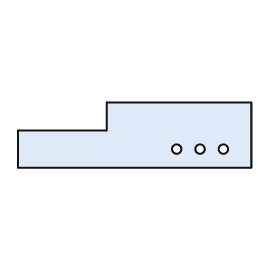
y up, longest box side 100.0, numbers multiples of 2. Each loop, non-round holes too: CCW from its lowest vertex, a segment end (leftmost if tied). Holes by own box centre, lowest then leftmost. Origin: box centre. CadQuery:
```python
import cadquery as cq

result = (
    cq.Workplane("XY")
    .moveTo(-50.0, -14.0)
    .lineTo(50.0, -14.0)
    .lineTo(50.0, 14.0)
    .lineTo(-12.0, 14.0)
    .lineTo(-12.0, 2.0)
    .lineTo(-50.0, 2.0)
    .close()
    .moveTo(18.0, -6.0)
    .circle(2.0)
    .moveTo(28.0, -6.0)
    .circle(2.0)
    .moveTo(38.0, -6.0)
    .circle(2.0)
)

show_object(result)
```